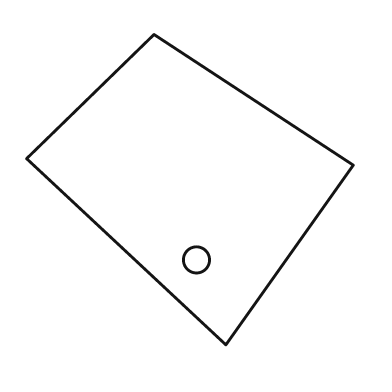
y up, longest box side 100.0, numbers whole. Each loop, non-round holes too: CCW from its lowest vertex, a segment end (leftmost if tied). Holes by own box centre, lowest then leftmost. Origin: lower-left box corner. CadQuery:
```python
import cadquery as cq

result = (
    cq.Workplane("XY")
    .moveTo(61.0, 0.0)
    .lineTo(100.0, 55.0)
    .lineTo(39.0, 95.0)
    .lineTo(0.0, 57.0)
    .close()
    .moveTo(52.0, 26.0)
    .circle(4.0)
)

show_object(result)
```